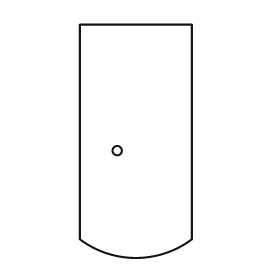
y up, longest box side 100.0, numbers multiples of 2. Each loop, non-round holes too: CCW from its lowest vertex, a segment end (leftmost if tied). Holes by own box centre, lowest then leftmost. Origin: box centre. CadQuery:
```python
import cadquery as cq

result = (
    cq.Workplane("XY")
    .moveTo(-24.0, -42.0)
    .threePointArc((0.0, -50.0), (24.0, -42.0))
    .lineTo(24.0, 50.0)
    .lineTo(-24.0, 50.0)
    .close()
    .moveTo(-8.0, -4.0)
    .circle(2.0)
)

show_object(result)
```